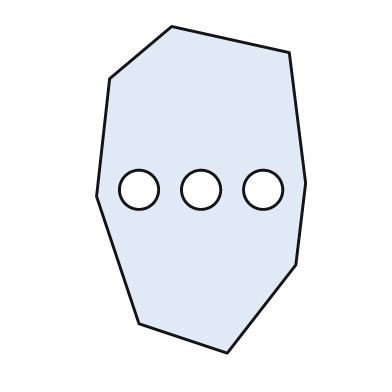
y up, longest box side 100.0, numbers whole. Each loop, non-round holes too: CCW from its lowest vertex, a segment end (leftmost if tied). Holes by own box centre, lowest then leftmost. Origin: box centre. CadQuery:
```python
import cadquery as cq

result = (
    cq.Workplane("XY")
    .moveTo(8.0, -50.0)
    .lineTo(29.0, -23.0)
    .lineTo(32.0, 2.0)
    .lineTo(27.0, 42.0)
    .lineTo(-9.0, 50.0)
    .lineTo(-28.0, 34.0)
    .lineTo(-32.0, -2.0)
    .lineTo(-19.0, -41.0)
    .close()
    .moveTo(-19.0, 0.0)
    .circle(6.0)
    .moveTo(0.0, 0.0)
    .circle(6.0)
    .moveTo(19.0, 0.0)
    .circle(6.0)
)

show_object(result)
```